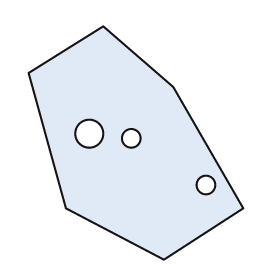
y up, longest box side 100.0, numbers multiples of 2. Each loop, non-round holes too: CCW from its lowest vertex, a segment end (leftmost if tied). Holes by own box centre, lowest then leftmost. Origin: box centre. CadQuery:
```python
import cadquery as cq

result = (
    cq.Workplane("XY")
    .moveTo(12.0, -50.0)
    .lineTo(46.0, -28.0)
    .lineTo(16.0, 24.0)
    .lineTo(-14.0, 50.0)
    .lineTo(-46.0, 30.0)
    .lineTo(-30.0, -28.0)
    .close()
    .moveTo(30.0, -18.0)
    .circle(4.0)
    .moveTo(-2.0, 2.0)
    .circle(4.0)
    .moveTo(-20.0, 4.0)
    .circle(6.0)
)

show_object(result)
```